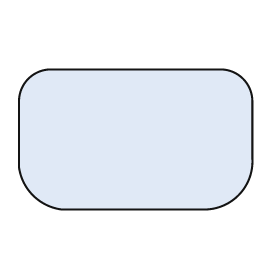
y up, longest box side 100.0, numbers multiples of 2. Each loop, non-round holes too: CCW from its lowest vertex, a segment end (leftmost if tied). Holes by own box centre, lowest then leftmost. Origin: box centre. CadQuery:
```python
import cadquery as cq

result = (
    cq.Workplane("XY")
    .moveTo(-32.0, -30.0)
    .lineTo(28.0, -30.0)
    .threePointArc((44.0, -24.0), (50.0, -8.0))
    .lineTo(50.0, 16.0)
    .threePointArc((46.0, 26.0), (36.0, 30.0))
    .lineTo(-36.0, 30.0)
    .threePointArc((-46.0, 26.0), (-50.0, 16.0))
    .lineTo(-50.0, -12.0)
    .threePointArc((-44.0, -24.0), (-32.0, -30.0))
    .close()
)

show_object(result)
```